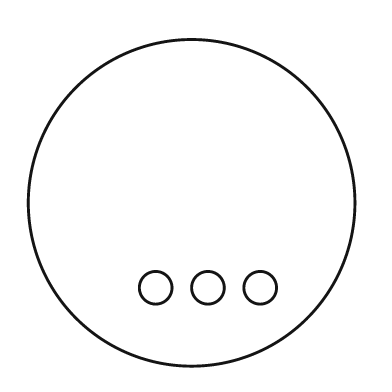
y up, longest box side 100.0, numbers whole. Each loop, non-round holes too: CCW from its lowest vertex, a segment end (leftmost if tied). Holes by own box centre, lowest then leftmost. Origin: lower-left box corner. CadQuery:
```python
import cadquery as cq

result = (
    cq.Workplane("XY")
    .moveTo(50.0, 50.0)
    .circle(50.0)
    .moveTo(39.0, 24.0)
    .circle(5.0)
    .moveTo(55.0, 24.0)
    .circle(5.0)
    .moveTo(71.0, 24.0)
    .circle(5.0)
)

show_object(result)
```